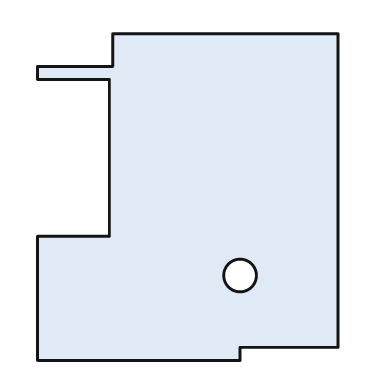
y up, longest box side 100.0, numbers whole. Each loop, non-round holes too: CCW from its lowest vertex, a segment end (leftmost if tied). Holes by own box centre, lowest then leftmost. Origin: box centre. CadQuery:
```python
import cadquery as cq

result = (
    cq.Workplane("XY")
    .moveTo(-46.0, -50.0)
    .lineTo(16.0, -50.0)
    .lineTo(16.0, -46.0)
    .lineTo(46.0, -46.0)
    .lineTo(46.0, 50.0)
    .lineTo(-23.0, 50.0)
    .lineTo(-23.0, 40.0)
    .lineTo(-46.0, 40.0)
    .lineTo(-46.0, 36.0)
    .lineTo(-24.0, 36.0)
    .lineTo(-24.0, -12.0)
    .lineTo(-46.0, -12.0)
    .close()
    .moveTo(16.0, -24.0)
    .circle(5.0)
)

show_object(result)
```